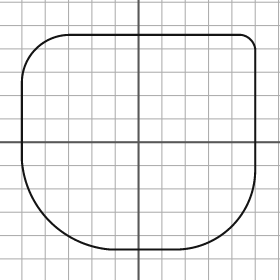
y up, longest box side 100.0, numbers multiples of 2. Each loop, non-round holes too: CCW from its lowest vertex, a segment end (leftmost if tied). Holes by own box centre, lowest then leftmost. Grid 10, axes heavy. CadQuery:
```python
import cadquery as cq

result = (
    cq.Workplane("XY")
    .moveTo(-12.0, -46.0)
    .lineTo(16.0, -46.0)
    .threePointArc((40.0, -36.0), (50.0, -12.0))
    .lineTo(50.0, 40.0)
    .threePointArc((48.0, 44.0), (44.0, 46.0))
    .lineTo(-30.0, 46.0)
    .threePointArc((-44.0, 40.0), (-50.0, 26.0))
    .lineTo(-50.0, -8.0)
    .threePointArc((-38.0, -34.0), (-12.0, -46.0))
    .close()
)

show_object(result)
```